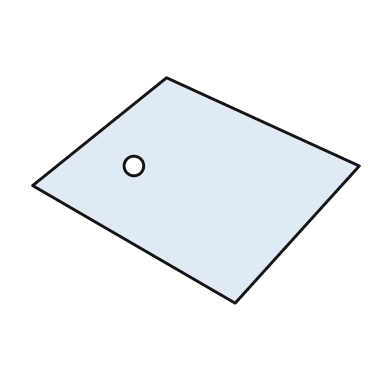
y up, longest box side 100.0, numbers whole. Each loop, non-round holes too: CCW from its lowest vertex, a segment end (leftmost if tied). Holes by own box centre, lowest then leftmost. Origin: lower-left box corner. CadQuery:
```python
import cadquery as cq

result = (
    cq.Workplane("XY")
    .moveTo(62.0, 0.0)
    .lineTo(100.0, 42.0)
    .lineTo(41.0, 69.0)
    .lineTo(0.0, 36.0)
    .close()
    .moveTo(31.0, 42.0)
    .circle(3.0)
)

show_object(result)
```